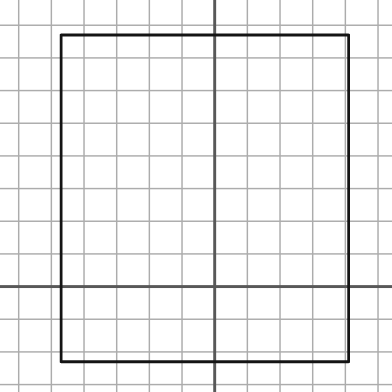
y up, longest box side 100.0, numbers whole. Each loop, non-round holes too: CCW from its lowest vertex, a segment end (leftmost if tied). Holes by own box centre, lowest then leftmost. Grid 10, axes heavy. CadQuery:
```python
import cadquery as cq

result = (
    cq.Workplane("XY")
    .moveTo(-47.0, -23.0)
    .lineTo(41.0, -23.0)
    .lineTo(41.0, 77.0)
    .lineTo(-47.0, 77.0)
    .close()
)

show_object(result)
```